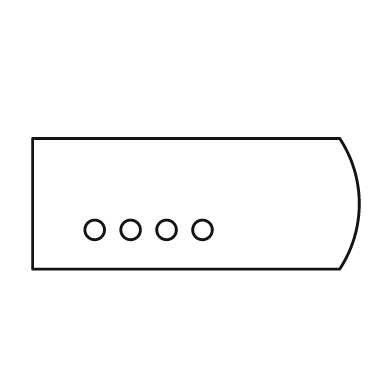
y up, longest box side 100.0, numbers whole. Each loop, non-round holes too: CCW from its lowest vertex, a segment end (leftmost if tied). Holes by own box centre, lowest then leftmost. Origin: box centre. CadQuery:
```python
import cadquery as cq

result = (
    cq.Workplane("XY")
    .moveTo(-50.0, -20.0)
    .lineTo(44.0, -20.0)
    .threePointArc((50.0, 0.0), (44.0, 20.0))
    .lineTo(-50.0, 20.0)
    .close()
    .moveTo(-31.0, -8.0)
    .circle(3.0)
    .moveTo(-20.0, -8.0)
    .circle(3.0)
    .moveTo(-9.0, -8.0)
    .circle(3.0)
    .moveTo(2.0, -8.0)
    .circle(3.0)
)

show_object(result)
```